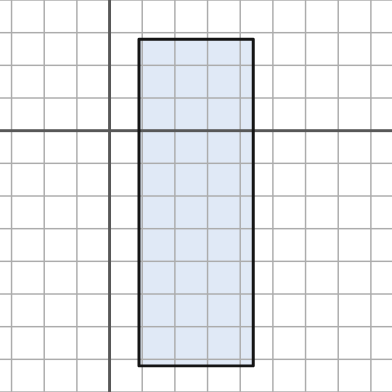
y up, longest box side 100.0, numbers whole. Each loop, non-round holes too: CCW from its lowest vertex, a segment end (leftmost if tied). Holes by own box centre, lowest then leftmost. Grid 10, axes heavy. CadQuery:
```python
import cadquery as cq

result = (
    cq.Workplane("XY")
    .moveTo(9.0, -72.0)
    .lineTo(44.0, -72.0)
    .lineTo(44.0, 28.0)
    .lineTo(9.0, 28.0)
    .close()
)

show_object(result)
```